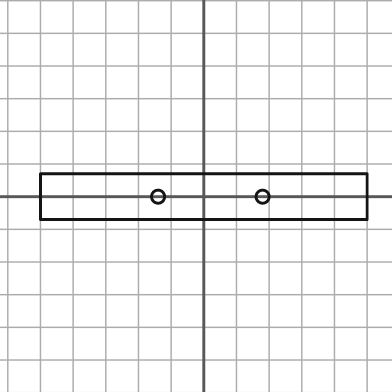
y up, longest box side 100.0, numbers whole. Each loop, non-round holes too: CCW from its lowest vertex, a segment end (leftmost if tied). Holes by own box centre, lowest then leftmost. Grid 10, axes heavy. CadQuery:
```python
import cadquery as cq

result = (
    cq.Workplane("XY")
    .moveTo(-50.0, -7.0)
    .lineTo(50.0, -7.0)
    .lineTo(50.0, 7.0)
    .lineTo(-50.0, 7.0)
    .close()
    .moveTo(-14.0, 0.0)
    .circle(2.0)
    .moveTo(18.0, 0.0)
    .circle(2.0)
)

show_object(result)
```